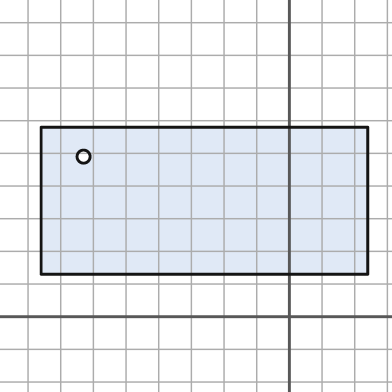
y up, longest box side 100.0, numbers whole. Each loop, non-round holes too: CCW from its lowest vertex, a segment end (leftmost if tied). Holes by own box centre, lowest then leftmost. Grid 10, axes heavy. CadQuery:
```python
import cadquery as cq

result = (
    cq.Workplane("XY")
    .moveTo(-76.0, 13.0)
    .lineTo(24.0, 13.0)
    .lineTo(24.0, 58.0)
    .lineTo(-76.0, 58.0)
    .close()
    .moveTo(-63.0, 49.0)
    .circle(2.0)
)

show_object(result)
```